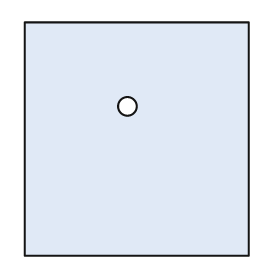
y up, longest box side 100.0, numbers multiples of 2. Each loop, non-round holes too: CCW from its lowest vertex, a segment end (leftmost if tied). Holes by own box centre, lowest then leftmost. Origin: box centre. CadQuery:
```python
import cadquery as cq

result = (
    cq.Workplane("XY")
    .moveTo(-48.0, -50.0)
    .lineTo(48.0, -50.0)
    .lineTo(48.0, 50.0)
    .lineTo(-48.0, 50.0)
    .close()
    .moveTo(-4.0, 14.0)
    .circle(4.0)
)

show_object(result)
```